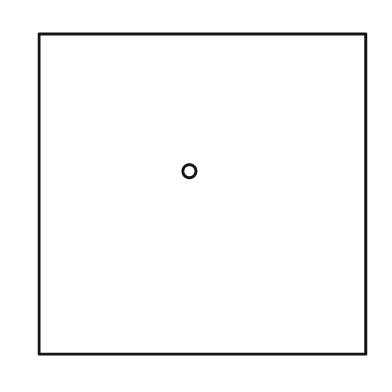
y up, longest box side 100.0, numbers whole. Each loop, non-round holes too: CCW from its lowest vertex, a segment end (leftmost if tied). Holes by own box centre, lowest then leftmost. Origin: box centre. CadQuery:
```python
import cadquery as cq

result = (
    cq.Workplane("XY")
    .moveTo(-50.0, -49.0)
    .lineTo(50.0, -49.0)
    .lineTo(50.0, 49.0)
    .lineTo(-50.0, 49.0)
    .close()
    .moveTo(-4.0, 7.0)
    .circle(2.0)
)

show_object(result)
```